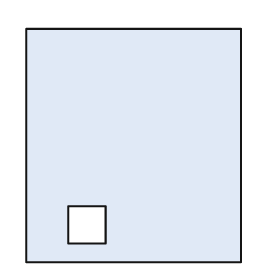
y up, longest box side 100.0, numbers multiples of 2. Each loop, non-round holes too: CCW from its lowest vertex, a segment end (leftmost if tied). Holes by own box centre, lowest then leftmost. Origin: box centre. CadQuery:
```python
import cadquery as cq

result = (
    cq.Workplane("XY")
    .moveTo(-46.0, -50.0)
    .lineTo(46.0, -50.0)
    .lineTo(46.0, 50.0)
    .lineTo(-46.0, 50.0)
    .close()
    .moveTo(-28.0, -42.0)
    .lineTo(-12.0, -42.0)
    .lineTo(-12.0, -26.0)
    .lineTo(-28.0, -26.0)
    .close()
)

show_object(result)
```